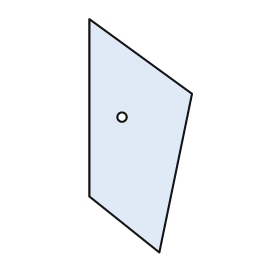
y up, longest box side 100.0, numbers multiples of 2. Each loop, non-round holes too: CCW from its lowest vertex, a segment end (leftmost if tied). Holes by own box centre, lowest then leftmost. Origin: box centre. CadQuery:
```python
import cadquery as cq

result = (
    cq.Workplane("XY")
    .moveTo(8.0, -50.0)
    .lineTo(22.0, 18.0)
    .lineTo(-22.0, 50.0)
    .lineTo(-22.0, -26.0)
    .close()
    .moveTo(-8.0, 8.0)
    .circle(2.0)
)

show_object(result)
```